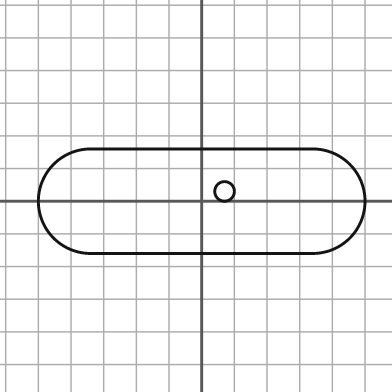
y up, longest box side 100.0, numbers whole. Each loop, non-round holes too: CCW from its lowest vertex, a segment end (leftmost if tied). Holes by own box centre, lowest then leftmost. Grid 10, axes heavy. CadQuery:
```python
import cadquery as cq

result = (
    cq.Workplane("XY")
    .moveTo(-34.0, -16.0)
    .lineTo(34.0, -16.0)
    .threePointArc((50.0, 0.0), (34.0, 16.0))
    .lineTo(-34.0, 16.0)
    .threePointArc((-50.0, 0.0), (-34.0, -16.0))
    .close()
    .moveTo(7.0, 3.0)
    .circle(3.0)
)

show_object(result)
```